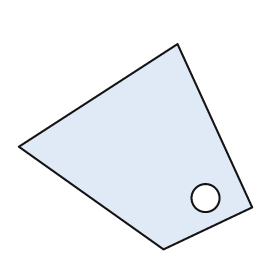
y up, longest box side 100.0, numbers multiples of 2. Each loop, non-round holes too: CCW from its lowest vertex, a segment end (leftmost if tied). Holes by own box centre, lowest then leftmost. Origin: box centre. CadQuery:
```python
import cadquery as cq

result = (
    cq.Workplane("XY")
    .moveTo(12.0, -44.0)
    .lineTo(50.0, -26.0)
    .lineTo(18.0, 44.0)
    .lineTo(-50.0, 0.0)
    .close()
    .moveTo(30.0, -22.0)
    .circle(6.0)
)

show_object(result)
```